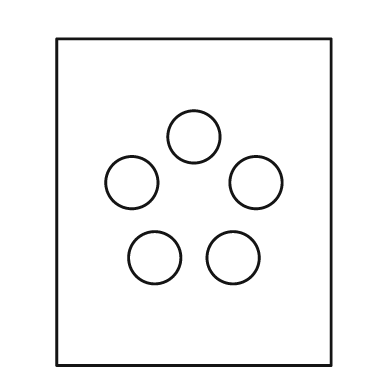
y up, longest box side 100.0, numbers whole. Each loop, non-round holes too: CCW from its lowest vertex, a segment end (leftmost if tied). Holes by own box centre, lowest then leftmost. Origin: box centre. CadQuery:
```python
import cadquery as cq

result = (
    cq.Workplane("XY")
    .moveTo(-42.0, -50.0)
    .lineTo(42.0, -50.0)
    .lineTo(42.0, 50.0)
    .lineTo(-42.0, 50.0)
    .close()
    .moveTo(-12.0, -17.0)
    .circle(8.0)
    .moveTo(12.0, -17.0)
    .circle(8.0)
    .moveTo(-19.0, 6.0)
    .circle(8.0)
    .moveTo(19.0, 6.0)
    .circle(8.0)
    .moveTo(0.0, 20.0)
    .circle(8.0)
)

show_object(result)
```